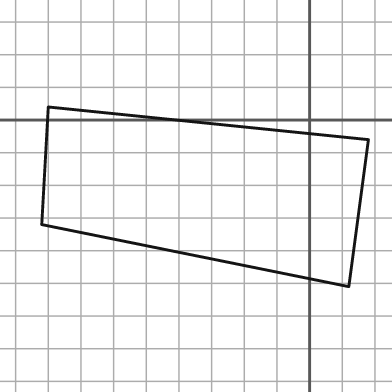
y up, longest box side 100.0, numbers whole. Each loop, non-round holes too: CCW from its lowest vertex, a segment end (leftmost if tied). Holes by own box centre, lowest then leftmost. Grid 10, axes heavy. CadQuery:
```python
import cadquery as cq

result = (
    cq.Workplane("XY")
    .moveTo(12.0, -51.0)
    .lineTo(18.0, -6.0)
    .lineTo(-80.0, 4.0)
    .lineTo(-82.0, -32.0)
    .close()
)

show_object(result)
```